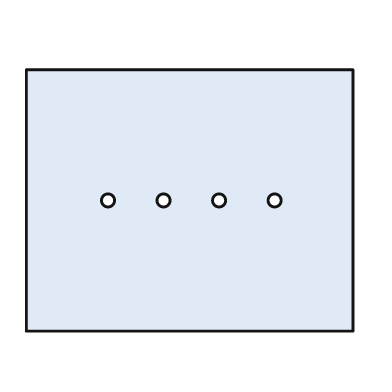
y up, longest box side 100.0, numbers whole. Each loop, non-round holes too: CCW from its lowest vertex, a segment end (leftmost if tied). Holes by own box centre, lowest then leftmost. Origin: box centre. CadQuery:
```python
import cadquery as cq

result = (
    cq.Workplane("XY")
    .moveTo(-50.0, -40.0)
    .lineTo(50.0, -40.0)
    .lineTo(50.0, 40.0)
    .lineTo(-50.0, 40.0)
    .close()
    .moveTo(-25.0, 0.0)
    .circle(2.0)
    .moveTo(-8.0, 0.0)
    .circle(2.0)
    .moveTo(9.0, 0.0)
    .circle(2.0)
    .moveTo(26.0, 0.0)
    .circle(2.0)
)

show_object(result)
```